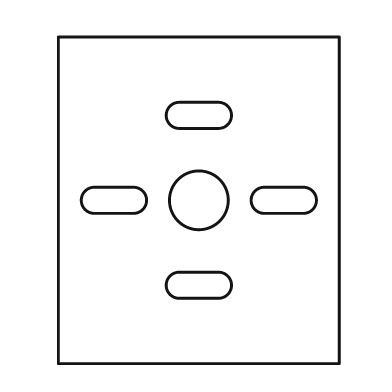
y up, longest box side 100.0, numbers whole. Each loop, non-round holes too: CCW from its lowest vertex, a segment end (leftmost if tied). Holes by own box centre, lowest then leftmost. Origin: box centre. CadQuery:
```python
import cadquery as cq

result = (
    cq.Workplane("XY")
    .moveTo(-43.0, -50.0)
    .lineTo(43.0, -50.0)
    .lineTo(43.0, 50.0)
    .lineTo(-43.0, 50.0)
    .close()
    .moveTo(-6.0, -30.0)
    .lineTo(6.0, -30.0)
    .threePointArc((10.0, -26.0), (6.0, -22.0))
    .lineTo(-6.0, -22.0)
    .threePointArc((-10.0, -26.0), (-6.0, -30.0))
    .close()
    .moveTo(-32.0, -4.0)
    .lineTo(-20.0, -4.0)
    .threePointArc((-16.0, 0.0), (-20.0, 4.0))
    .lineTo(-32.0, 4.0)
    .threePointArc((-36.0, 0.0), (-32.0, -4.0))
    .close()
    .moveTo(0.0, 0.0)
    .circle(9.0)
    .moveTo(20.0, -4.0)
    .lineTo(32.0, -4.0)
    .threePointArc((36.0, 0.0), (32.0, 4.0))
    .lineTo(20.0, 4.0)
    .threePointArc((16.0, 0.0), (20.0, -4.0))
    .close()
    .moveTo(-6.0, 22.0)
    .lineTo(6.0, 22.0)
    .threePointArc((10.0, 26.0), (6.0, 30.0))
    .lineTo(-6.0, 30.0)
    .threePointArc((-10.0, 26.0), (-6.0, 22.0))
    .close()
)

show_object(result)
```